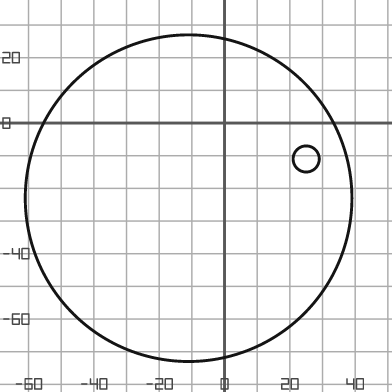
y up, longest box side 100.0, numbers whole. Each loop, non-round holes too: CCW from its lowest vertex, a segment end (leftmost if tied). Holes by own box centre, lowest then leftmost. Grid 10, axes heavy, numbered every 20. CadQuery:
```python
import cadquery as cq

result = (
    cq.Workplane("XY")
    .moveTo(-11.0, -23.0)
    .circle(50.0)
    .moveTo(25.0, -11.0)
    .circle(4.0)
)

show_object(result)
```